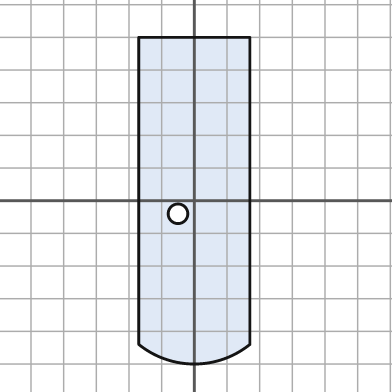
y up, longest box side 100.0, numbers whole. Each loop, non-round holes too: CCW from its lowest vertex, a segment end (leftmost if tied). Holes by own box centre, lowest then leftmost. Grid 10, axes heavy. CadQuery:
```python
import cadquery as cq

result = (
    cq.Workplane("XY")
    .moveTo(-17.0, -44.0)
    .threePointArc((0.0, -50.0), (17.0, -44.0))
    .lineTo(17.0, 50.0)
    .lineTo(-17.0, 50.0)
    .close()
    .moveTo(-5.0, -4.0)
    .circle(3.0)
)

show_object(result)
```